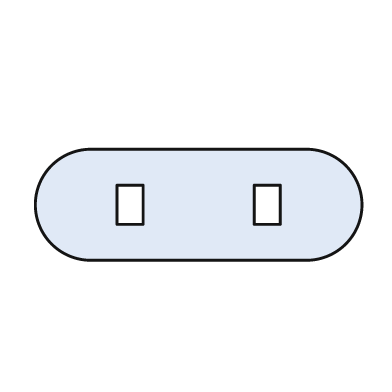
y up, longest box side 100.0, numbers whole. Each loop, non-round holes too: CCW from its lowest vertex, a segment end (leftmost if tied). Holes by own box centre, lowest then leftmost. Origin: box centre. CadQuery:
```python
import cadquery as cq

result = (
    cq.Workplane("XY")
    .moveTo(-33.0, -17.0)
    .lineTo(33.0, -17.0)
    .threePointArc((50.0, 0.0), (33.0, 17.0))
    .lineTo(-33.0, 17.0)
    .threePointArc((-50.0, 0.0), (-33.0, -17.0))
    .close()
    .moveTo(-25.0, -6.0)
    .lineTo(-17.0, -6.0)
    .lineTo(-17.0, 6.0)
    .lineTo(-25.0, 6.0)
    .close()
    .moveTo(17.0, -6.0)
    .lineTo(25.0, -6.0)
    .lineTo(25.0, 6.0)
    .lineTo(17.0, 6.0)
    .close()
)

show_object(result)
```